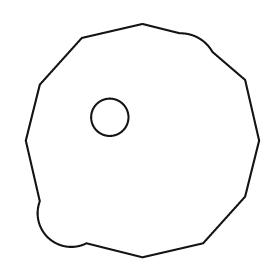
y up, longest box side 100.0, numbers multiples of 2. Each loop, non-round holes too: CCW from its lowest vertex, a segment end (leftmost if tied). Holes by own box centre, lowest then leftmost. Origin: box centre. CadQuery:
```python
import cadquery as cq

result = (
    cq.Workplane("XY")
    .moveTo(0.0, -50.0)
    .lineTo(26.0, -44.0)
    .lineTo(44.0, -24.0)
    .lineTo(50.0, 0.0)
    .lineTo(44.0, 26.0)
    .lineTo(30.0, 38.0)
    .threePointArc((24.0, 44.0), (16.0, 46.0))
    .lineTo(0.0, 50.0)
    .lineTo(-26.0, 44.0)
    .lineTo(-44.0, 24.0)
    .lineTo(-50.0, 0.0)
    .lineTo(-44.0, -26.0)
    .threePointArc((-40.0, -42.0), (-24.0, -44.0))
    .close()
    .moveTo(-14.0, 10.0)
    .circle(8.0)
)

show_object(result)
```